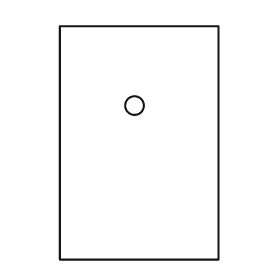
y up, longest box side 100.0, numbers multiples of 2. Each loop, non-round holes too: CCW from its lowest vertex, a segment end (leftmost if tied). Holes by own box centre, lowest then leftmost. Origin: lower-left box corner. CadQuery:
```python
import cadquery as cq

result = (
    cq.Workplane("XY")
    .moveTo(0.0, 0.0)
    .lineTo(68.0, 0.0)
    .lineTo(68.0, 100.0)
    .lineTo(0.0, 100.0)
    .close()
    .moveTo(32.0, 66.0)
    .circle(4.0)
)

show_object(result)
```